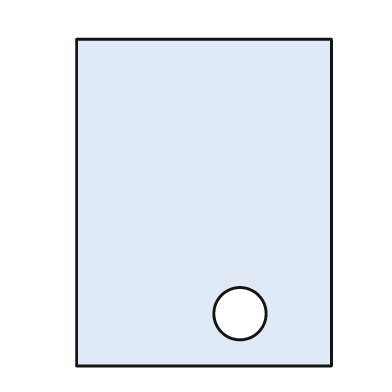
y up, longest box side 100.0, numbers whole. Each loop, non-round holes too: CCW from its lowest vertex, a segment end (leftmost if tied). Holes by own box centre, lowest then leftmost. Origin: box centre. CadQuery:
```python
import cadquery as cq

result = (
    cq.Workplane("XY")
    .moveTo(-39.0, -50.0)
    .lineTo(39.0, -50.0)
    .lineTo(39.0, 50.0)
    .lineTo(-39.0, 50.0)
    .close()
    .moveTo(11.0, -34.0)
    .circle(8.0)
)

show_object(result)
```